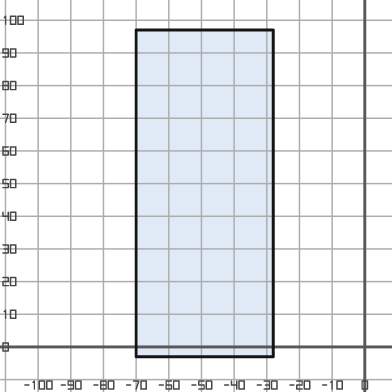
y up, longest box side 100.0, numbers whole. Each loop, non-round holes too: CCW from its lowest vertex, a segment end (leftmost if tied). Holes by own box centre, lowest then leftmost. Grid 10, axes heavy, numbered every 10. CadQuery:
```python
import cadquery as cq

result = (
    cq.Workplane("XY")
    .moveTo(-70.0, -3.0)
    .lineTo(-28.0, -3.0)
    .lineTo(-28.0, 97.0)
    .lineTo(-70.0, 97.0)
    .close()
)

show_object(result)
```